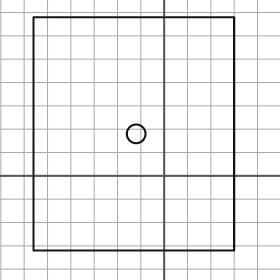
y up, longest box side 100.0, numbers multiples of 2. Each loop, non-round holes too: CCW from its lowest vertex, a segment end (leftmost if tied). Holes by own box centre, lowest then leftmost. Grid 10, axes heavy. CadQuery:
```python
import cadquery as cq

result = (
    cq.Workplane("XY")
    .moveTo(-56.0, -32.0)
    .lineTo(30.0, -32.0)
    .lineTo(30.0, 68.0)
    .lineTo(-56.0, 68.0)
    .close()
    .moveTo(-12.0, 18.0)
    .circle(4.0)
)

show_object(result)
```